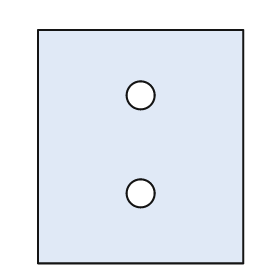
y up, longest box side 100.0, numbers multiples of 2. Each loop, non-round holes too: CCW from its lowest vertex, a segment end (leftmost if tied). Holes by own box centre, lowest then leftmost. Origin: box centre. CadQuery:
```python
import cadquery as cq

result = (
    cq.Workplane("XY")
    .moveTo(-44.0, -50.0)
    .lineTo(44.0, -50.0)
    .lineTo(44.0, 50.0)
    .lineTo(-44.0, 50.0)
    .close()
    .moveTo(0.0, -20.0)
    .circle(6.0)
    .moveTo(0.0, 22.0)
    .circle(6.0)
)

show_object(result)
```